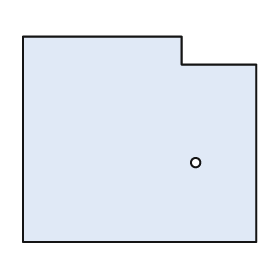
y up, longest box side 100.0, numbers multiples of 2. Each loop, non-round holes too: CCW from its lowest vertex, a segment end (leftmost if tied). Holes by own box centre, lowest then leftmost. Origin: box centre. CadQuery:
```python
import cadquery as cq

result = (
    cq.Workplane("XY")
    .moveTo(-50.0, -44.0)
    .lineTo(50.0, -44.0)
    .lineTo(50.0, 32.0)
    .lineTo(18.0, 32.0)
    .lineTo(18.0, 44.0)
    .lineTo(-50.0, 44.0)
    .close()
    .moveTo(24.0, -10.0)
    .circle(2.0)
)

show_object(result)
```